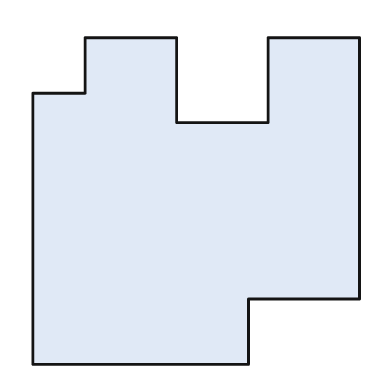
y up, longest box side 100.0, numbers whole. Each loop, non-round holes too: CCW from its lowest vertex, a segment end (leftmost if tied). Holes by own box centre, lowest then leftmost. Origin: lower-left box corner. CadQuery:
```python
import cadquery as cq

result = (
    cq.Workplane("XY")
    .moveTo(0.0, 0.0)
    .lineTo(66.0, 0.0)
    .lineTo(66.0, 20.0)
    .lineTo(100.0, 20.0)
    .lineTo(100.0, 100.0)
    .lineTo(72.0, 100.0)
    .lineTo(72.0, 74.0)
    .lineTo(44.0, 74.0)
    .lineTo(44.0, 100.0)
    .lineTo(16.0, 100.0)
    .lineTo(16.0, 83.0)
    .lineTo(0.0, 83.0)
    .close()
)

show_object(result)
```